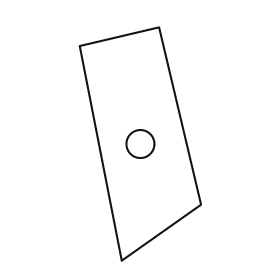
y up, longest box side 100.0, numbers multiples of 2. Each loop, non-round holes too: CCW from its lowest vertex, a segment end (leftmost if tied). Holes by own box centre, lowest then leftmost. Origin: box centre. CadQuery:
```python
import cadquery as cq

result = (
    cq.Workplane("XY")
    .moveTo(-8.0, -50.0)
    .lineTo(26.0, -26.0)
    .lineTo(8.0, 50.0)
    .lineTo(-26.0, 42.0)
    .close()
    .moveTo(0.0, 0.0)
    .circle(6.0)
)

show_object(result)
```